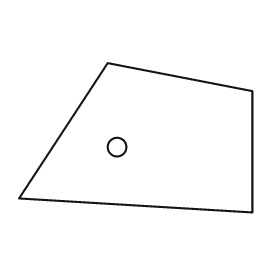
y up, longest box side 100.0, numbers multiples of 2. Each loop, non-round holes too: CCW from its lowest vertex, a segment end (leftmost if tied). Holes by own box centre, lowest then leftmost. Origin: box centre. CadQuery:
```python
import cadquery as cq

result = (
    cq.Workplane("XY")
    .moveTo(50.0, -32.0)
    .lineTo(50.0, 20.0)
    .lineTo(-12.0, 32.0)
    .lineTo(-50.0, -26.0)
    .close()
    .moveTo(-8.0, -4.0)
    .circle(4.0)
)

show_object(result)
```